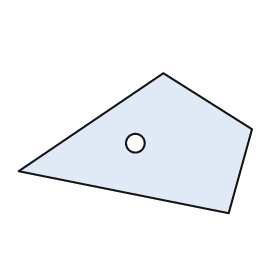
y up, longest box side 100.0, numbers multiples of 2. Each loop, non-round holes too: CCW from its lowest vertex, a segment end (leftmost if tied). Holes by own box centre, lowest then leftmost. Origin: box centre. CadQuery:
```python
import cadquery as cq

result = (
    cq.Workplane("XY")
    .moveTo(40.0, -30.0)
    .lineTo(50.0, 6.0)
    .lineTo(12.0, 30.0)
    .lineTo(-50.0, -12.0)
    .close()
    .moveTo(0.0, 0.0)
    .circle(4.0)
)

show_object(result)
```